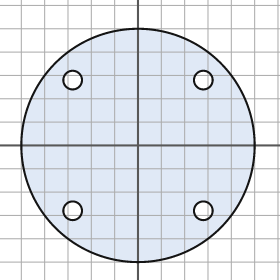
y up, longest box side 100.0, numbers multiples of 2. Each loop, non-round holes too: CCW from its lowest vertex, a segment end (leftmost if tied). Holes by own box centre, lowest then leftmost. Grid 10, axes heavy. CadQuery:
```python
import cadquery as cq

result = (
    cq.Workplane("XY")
    .moveTo(0.0, 0.0)
    .circle(50.0)
    .moveTo(-28.0, -28.0)
    .circle(4.0)
    .moveTo(28.0, -28.0)
    .circle(4.0)
    .moveTo(-28.0, 28.0)
    .circle(4.0)
    .moveTo(28.0, 28.0)
    .circle(4.0)
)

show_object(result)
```